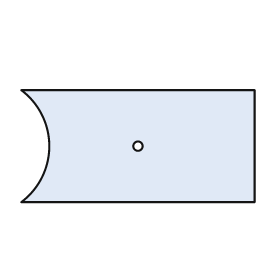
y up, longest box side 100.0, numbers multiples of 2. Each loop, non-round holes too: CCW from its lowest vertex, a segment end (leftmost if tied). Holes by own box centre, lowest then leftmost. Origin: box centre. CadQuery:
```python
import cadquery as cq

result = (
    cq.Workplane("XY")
    .moveTo(-50.0, -24.0)
    .lineTo(50.0, -24.0)
    .lineTo(50.0, 24.0)
    .lineTo(-50.0, 24.0)
    .threePointArc((-38.0, 0.0), (-50.0, -24.0))
    .close()
    .moveTo(0.0, 0.0)
    .circle(2.0)
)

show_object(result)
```